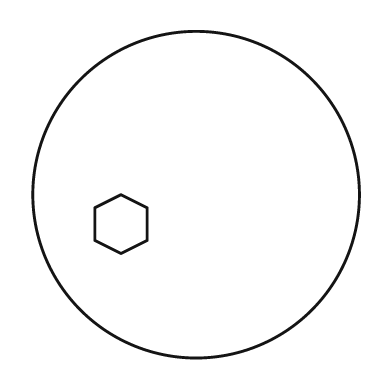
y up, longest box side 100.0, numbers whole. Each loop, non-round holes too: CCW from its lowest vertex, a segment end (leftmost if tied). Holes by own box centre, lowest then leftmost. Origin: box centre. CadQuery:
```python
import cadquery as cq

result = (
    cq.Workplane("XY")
    .moveTo(0.0, 0.0)
    .circle(50.0)
    .moveTo(-23.0, -18.0)
    .lineTo(-15.0, -14.0)
    .lineTo(-15.0, -4.0)
    .lineTo(-23.0, 0.0)
    .lineTo(-31.0, -4.0)
    .lineTo(-31.0, -14.0)
    .close()
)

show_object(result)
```